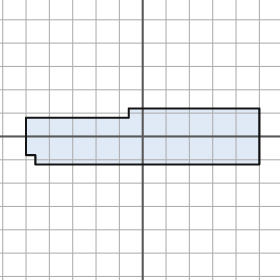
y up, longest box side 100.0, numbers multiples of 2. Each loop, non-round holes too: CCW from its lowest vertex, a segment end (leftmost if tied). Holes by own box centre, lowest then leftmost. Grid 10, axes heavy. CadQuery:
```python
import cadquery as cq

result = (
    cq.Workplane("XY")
    .moveTo(-46.0, -12.0)
    .lineTo(50.0, -12.0)
    .lineTo(50.0, 12.0)
    .lineTo(-6.0, 12.0)
    .lineTo(-6.0, 8.0)
    .lineTo(-50.0, 8.0)
    .lineTo(-50.0, -8.0)
    .lineTo(-46.0, -8.0)
    .close()
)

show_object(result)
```